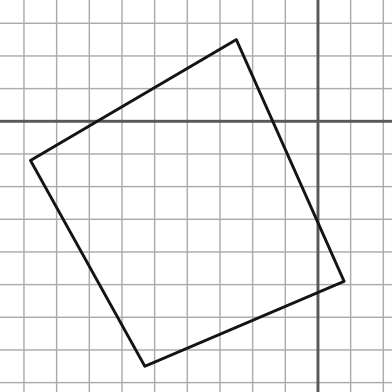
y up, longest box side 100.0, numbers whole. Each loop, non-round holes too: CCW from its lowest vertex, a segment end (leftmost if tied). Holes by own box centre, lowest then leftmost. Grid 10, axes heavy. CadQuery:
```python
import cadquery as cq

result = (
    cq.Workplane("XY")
    .moveTo(-53.0, -75.0)
    .lineTo(8.0, -49.0)
    .lineTo(-25.0, 25.0)
    .lineTo(-88.0, -12.0)
    .close()
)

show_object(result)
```